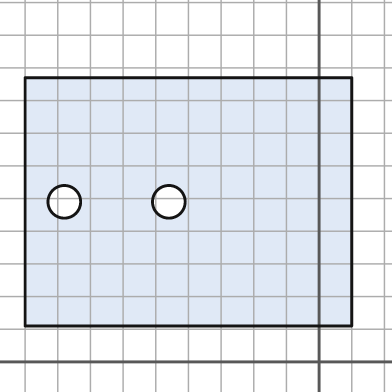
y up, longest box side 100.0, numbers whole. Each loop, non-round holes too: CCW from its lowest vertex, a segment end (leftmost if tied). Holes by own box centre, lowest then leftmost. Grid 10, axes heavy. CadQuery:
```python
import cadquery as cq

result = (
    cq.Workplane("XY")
    .moveTo(-90.0, 11.0)
    .lineTo(10.0, 11.0)
    .lineTo(10.0, 87.0)
    .lineTo(-90.0, 87.0)
    .close()
    .moveTo(-78.0, 49.0)
    .circle(5.0)
    .moveTo(-46.0, 49.0)
    .circle(5.0)
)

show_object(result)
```